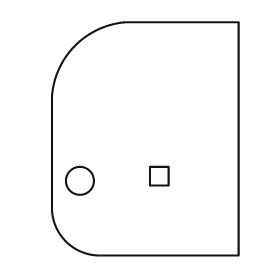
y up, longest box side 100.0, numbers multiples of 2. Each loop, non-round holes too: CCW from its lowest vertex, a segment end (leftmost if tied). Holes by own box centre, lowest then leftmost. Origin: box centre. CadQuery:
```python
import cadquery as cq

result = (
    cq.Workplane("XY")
    .moveTo(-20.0, -50.0)
    .lineTo(40.0, -50.0)
    .lineTo(40.0, 50.0)
    .lineTo(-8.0, 50.0)
    .threePointArc((-30.0, 40.0), (-40.0, 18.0))
    .lineTo(-40.0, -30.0)
    .threePointArc((-34.0, -44.0), (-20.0, -50.0))
    .close()
    .moveTo(-28.0, -18.0)
    .circle(6.0)
    .moveTo(2.0, -20.0)
    .lineTo(10.0, -20.0)
    .lineTo(10.0, -12.0)
    .lineTo(2.0, -12.0)
    .close()
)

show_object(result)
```